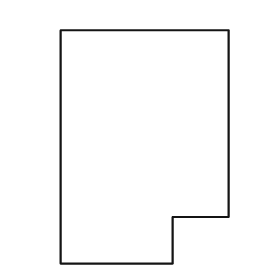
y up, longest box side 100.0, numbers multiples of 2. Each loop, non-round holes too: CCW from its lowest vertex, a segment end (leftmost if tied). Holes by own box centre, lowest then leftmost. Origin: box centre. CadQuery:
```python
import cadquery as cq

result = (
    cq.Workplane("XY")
    .moveTo(-36.0, -50.0)
    .lineTo(12.0, -50.0)
    .lineTo(12.0, -30.0)
    .lineTo(36.0, -30.0)
    .lineTo(36.0, 50.0)
    .lineTo(-36.0, 50.0)
    .close()
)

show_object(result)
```